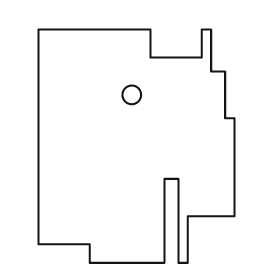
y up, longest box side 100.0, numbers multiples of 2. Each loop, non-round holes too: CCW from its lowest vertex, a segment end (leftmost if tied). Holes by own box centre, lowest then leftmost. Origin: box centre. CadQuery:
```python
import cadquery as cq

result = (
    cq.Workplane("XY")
    .moveTo(-20.0, -50.0)
    .lineTo(12.0, -50.0)
    .lineTo(12.0, -14.0)
    .lineTo(18.0, -14.0)
    .lineTo(18.0, -50.0)
    .lineTo(22.0, -50.0)
    .lineTo(22.0, -30.0)
    .lineTo(42.0, -30.0)
    .lineTo(42.0, 12.0)
    .lineTo(38.0, 12.0)
    .lineTo(38.0, 32.0)
    .lineTo(32.0, 32.0)
    .lineTo(32.0, 50.0)
    .lineTo(28.0, 50.0)
    .lineTo(28.0, 38.0)
    .lineTo(6.0, 38.0)
    .lineTo(6.0, 50.0)
    .lineTo(-42.0, 50.0)
    .lineTo(-42.0, -42.0)
    .lineTo(-20.0, -42.0)
    .close()
    .moveTo(-2.0, 22.0)
    .circle(4.0)
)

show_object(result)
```